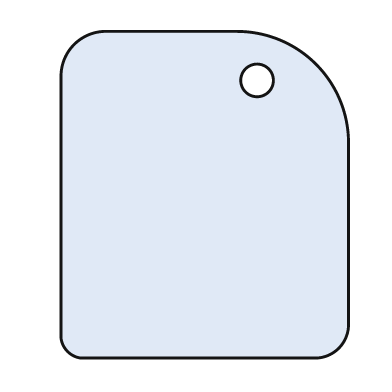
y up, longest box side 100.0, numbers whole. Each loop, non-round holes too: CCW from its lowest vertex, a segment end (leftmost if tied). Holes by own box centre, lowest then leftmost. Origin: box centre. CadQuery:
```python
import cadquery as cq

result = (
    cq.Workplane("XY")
    .moveTo(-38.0, -50.0)
    .lineTo(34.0, -50.0)
    .threePointArc((41.0, -47.0), (44.0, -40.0))
    .lineTo(44.0, 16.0)
    .threePointArc((34.0, 40.0), (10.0, 50.0))
    .lineTo(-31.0, 50.0)
    .threePointArc((-40.0, 46.0), (-44.0, 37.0))
    .lineTo(-44.0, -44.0)
    .threePointArc((-42.0, -48.0), (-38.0, -50.0))
    .close()
    .moveTo(16.0, 35.0)
    .circle(5.0)
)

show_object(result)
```